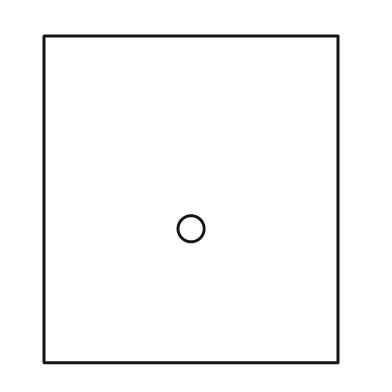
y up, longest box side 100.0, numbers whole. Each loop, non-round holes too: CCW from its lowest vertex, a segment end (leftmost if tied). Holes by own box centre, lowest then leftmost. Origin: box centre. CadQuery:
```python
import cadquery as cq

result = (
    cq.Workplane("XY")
    .moveTo(-45.0, -50.0)
    .lineTo(45.0, -50.0)
    .lineTo(45.0, 50.0)
    .lineTo(-45.0, 50.0)
    .close()
    .moveTo(0.0, -9.0)
    .circle(4.0)
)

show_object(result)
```